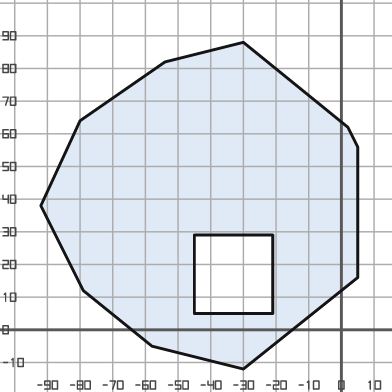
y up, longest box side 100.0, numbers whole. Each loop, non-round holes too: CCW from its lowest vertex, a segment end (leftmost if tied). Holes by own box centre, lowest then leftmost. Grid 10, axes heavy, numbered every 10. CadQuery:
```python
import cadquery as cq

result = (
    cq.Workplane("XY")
    .moveTo(-30.0, -12.0)
    .lineTo(5.0, 16.0)
    .lineTo(5.0, 56.0)
    .lineTo(2.0, 62.0)
    .lineTo(-30.0, 88.0)
    .lineTo(-54.0, 82.0)
    .lineTo(-80.0, 64.0)
    .lineTo(-92.0, 38.0)
    .lineTo(-79.0, 12.0)
    .lineTo(-58.0, -5.0)
    .close()
    .moveTo(-45.0, 5.0)
    .lineTo(-21.0, 5.0)
    .lineTo(-21.0, 29.0)
    .lineTo(-45.0, 29.0)
    .close()
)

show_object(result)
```